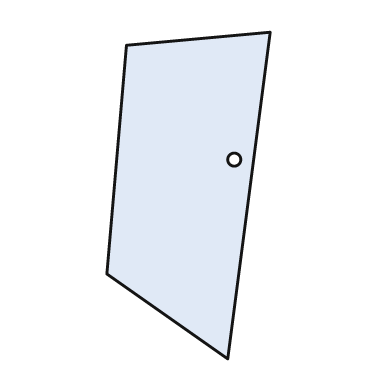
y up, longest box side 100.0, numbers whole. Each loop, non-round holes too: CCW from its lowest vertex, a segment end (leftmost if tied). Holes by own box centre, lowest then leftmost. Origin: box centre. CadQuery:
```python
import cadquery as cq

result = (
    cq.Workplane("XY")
    .moveTo(12.0, -50.0)
    .lineTo(25.0, 50.0)
    .lineTo(-19.0, 46.0)
    .lineTo(-25.0, -24.0)
    .close()
    .moveTo(14.0, 11.0)
    .circle(2.0)
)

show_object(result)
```